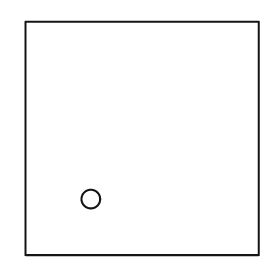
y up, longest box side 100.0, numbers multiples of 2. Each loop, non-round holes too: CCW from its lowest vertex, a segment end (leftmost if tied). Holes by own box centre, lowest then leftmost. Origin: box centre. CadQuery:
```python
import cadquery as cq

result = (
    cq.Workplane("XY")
    .moveTo(-50.0, -50.0)
    .lineTo(50.0, -50.0)
    .lineTo(50.0, 50.0)
    .lineTo(-50.0, 50.0)
    .close()
    .moveTo(-22.0, -26.0)
    .circle(4.0)
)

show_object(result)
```